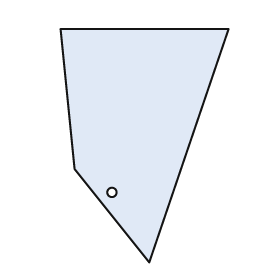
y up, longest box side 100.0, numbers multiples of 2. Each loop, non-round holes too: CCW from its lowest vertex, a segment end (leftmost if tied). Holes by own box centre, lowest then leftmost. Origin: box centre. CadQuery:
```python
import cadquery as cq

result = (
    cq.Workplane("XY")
    .moveTo(2.0, -50.0)
    .lineTo(36.0, 50.0)
    .lineTo(-36.0, 50.0)
    .lineTo(-30.0, -10.0)
    .close()
    .moveTo(-14.0, -20.0)
    .circle(2.0)
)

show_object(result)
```